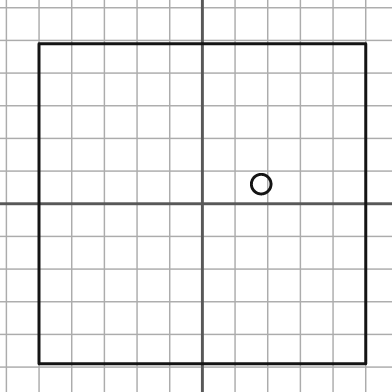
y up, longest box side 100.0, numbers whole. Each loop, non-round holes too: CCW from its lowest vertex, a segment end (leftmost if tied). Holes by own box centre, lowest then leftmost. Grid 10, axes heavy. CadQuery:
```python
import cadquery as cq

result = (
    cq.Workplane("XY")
    .moveTo(-50.0, -49.0)
    .lineTo(50.0, -49.0)
    .lineTo(50.0, 49.0)
    .lineTo(-50.0, 49.0)
    .close()
    .moveTo(18.0, 6.0)
    .circle(3.0)
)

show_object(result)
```